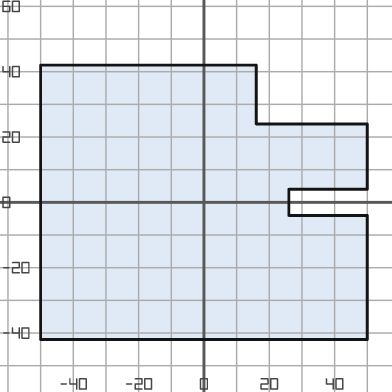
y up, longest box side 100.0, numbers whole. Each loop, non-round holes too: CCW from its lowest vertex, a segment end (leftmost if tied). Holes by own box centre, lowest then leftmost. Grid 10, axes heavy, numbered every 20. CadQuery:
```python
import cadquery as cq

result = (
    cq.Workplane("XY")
    .moveTo(-50.0, -42.0)
    .lineTo(50.0, -42.0)
    .lineTo(50.0, -4.0)
    .lineTo(26.0, -4.0)
    .lineTo(26.0, 4.0)
    .lineTo(50.0, 4.0)
    .lineTo(50.0, 24.0)
    .lineTo(16.0, 24.0)
    .lineTo(16.0, 42.0)
    .lineTo(-50.0, 42.0)
    .close()
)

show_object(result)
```